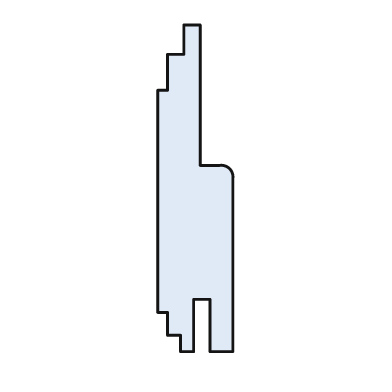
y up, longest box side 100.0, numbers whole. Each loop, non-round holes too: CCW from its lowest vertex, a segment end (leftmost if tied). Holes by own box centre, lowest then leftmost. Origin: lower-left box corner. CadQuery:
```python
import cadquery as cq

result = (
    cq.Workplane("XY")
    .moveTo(7.0, 0.0)
    .lineTo(11.0, 0.0)
    .lineTo(11.0, 16.0)
    .lineTo(16.0, 16.0)
    .lineTo(16.0, 0.0)
    .lineTo(23.0, 0.0)
    .lineTo(23.0, 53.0)
    .threePointArc((22.0, 56.0), (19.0, 57.0))
    .lineTo(13.0, 57.0)
    .lineTo(13.0, 100.0)
    .lineTo(8.0, 100.0)
    .lineTo(8.0, 91.0)
    .lineTo(3.0, 91.0)
    .lineTo(3.0, 80.0)
    .lineTo(0.0, 80.0)
    .lineTo(0.0, 12.0)
    .lineTo(3.0, 12.0)
    .lineTo(3.0, 5.0)
    .lineTo(7.0, 5.0)
    .close()
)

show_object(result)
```